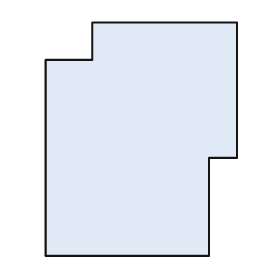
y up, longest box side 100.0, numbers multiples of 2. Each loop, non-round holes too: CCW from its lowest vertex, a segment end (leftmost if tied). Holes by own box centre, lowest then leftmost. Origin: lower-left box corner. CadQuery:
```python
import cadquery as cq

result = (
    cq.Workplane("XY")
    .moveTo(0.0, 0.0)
    .lineTo(70.0, 0.0)
    .lineTo(70.0, 42.0)
    .lineTo(82.0, 42.0)
    .lineTo(82.0, 100.0)
    .lineTo(20.0, 100.0)
    .lineTo(20.0, 84.0)
    .lineTo(0.0, 84.0)
    .close()
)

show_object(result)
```